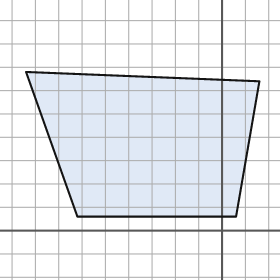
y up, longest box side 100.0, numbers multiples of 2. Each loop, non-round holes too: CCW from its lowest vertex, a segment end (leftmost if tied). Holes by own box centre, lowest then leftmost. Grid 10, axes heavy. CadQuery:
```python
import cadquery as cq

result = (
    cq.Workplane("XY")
    .moveTo(-62.0, 6.0)
    .lineTo(6.0, 6.0)
    .lineTo(16.0, 64.0)
    .lineTo(-84.0, 68.0)
    .close()
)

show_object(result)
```